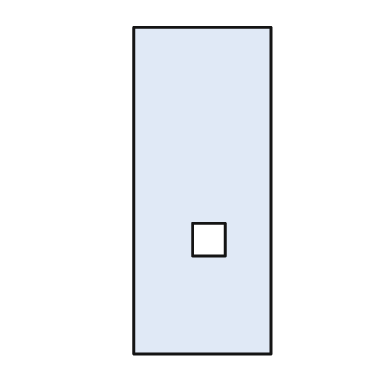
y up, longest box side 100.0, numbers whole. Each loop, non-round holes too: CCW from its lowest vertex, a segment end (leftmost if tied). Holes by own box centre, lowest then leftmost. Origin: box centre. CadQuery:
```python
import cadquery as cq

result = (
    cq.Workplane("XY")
    .moveTo(-21.0, -50.0)
    .lineTo(21.0, -50.0)
    .lineTo(21.0, 50.0)
    .lineTo(-21.0, 50.0)
    .close()
    .moveTo(-3.0, -20.0)
    .lineTo(7.0, -20.0)
    .lineTo(7.0, -10.0)
    .lineTo(-3.0, -10.0)
    .close()
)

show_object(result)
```